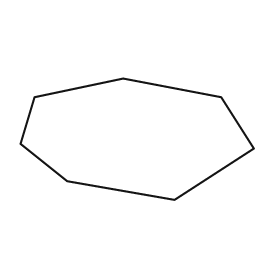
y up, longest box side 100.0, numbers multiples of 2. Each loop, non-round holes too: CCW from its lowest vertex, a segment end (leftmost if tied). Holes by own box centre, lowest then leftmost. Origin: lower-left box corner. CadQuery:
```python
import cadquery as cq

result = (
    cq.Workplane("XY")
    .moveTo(66.0, 0.0)
    .lineTo(100.0, 22.0)
    .lineTo(86.0, 44.0)
    .lineTo(44.0, 52.0)
    .lineTo(6.0, 44.0)
    .lineTo(0.0, 24.0)
    .lineTo(20.0, 8.0)
    .close()
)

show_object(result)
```